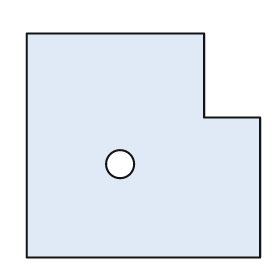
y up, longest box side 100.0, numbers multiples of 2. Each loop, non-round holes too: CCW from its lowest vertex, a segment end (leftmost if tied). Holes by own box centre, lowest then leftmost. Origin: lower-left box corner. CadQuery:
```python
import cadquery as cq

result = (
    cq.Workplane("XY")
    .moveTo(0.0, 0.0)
    .lineTo(100.0, 0.0)
    .lineTo(100.0, 60.0)
    .lineTo(76.0, 60.0)
    .lineTo(76.0, 96.0)
    .lineTo(0.0, 96.0)
    .close()
    .moveTo(40.0, 40.0)
    .circle(6.0)
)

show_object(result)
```